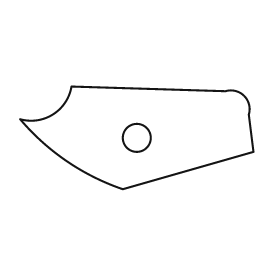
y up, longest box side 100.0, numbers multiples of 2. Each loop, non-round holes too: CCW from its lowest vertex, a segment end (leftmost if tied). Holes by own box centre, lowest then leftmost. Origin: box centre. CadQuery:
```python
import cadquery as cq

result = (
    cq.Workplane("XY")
    .moveTo(-6.0, -22.0)
    .lineTo(50.0, -6.0)
    .lineTo(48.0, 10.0)
    .threePointArc((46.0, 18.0), (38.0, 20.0))
    .lineTo(-28.0, 22.0)
    .threePointArc((-36.0, 10.0), (-50.0, 8.0))
    .threePointArc((-30.0, -10.0), (-6.0, -22.0))
    .close()
    .moveTo(0.0, 0.0)
    .circle(6.0)
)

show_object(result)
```